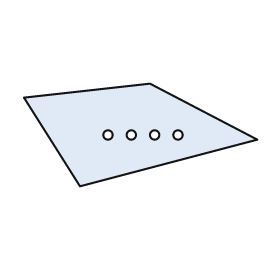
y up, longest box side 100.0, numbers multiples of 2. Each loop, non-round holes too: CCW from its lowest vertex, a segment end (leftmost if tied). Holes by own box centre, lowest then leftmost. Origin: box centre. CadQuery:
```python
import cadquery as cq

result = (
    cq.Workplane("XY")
    .moveTo(-26.0, -22.0)
    .lineTo(50.0, -2.0)
    .lineTo(4.0, 22.0)
    .lineTo(-50.0, 16.0)
    .close()
    .moveTo(-14.0, 0.0)
    .circle(2.0)
    .moveTo(-4.0, 0.0)
    .circle(2.0)
    .moveTo(6.0, 0.0)
    .circle(2.0)
    .moveTo(16.0, 0.0)
    .circle(2.0)
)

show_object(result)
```